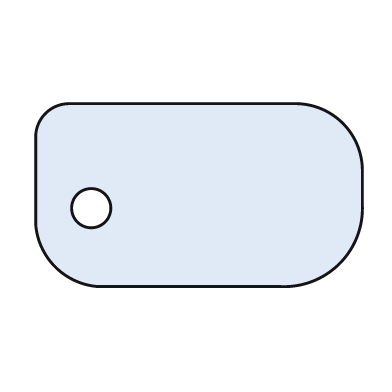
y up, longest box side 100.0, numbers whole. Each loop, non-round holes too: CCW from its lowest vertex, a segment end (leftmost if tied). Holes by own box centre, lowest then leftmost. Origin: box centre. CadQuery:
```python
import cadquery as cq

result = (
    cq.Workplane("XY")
    .moveTo(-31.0, -28.0)
    .lineTo(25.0, -28.0)
    .threePointArc((43.0, -21.0), (50.0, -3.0))
    .lineTo(50.0, 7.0)
    .threePointArc((44.0, 22.0), (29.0, 28.0))
    .lineTo(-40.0, 28.0)
    .threePointArc((-47.0, 25.0), (-50.0, 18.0))
    .lineTo(-50.0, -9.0)
    .threePointArc((-44.0, -22.0), (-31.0, -28.0))
    .close()
    .moveTo(-33.0, -4.0)
    .circle(6.0)
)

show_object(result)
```